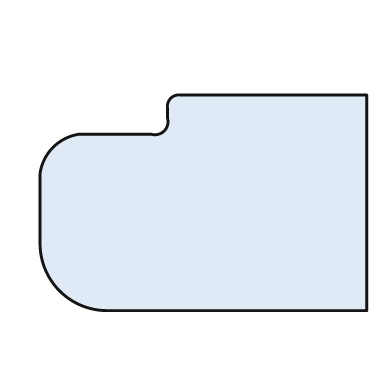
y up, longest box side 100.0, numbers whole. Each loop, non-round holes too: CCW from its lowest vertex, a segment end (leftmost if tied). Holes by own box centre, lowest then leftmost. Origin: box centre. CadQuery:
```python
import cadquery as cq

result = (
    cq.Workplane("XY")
    .moveTo(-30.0, -33.0)
    .lineTo(50.0, -33.0)
    .lineTo(50.0, 33.0)
    .lineTo(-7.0, 33.0)
    .threePointArc((-10.0, 32.0), (-11.0, 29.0))
    .lineTo(-11.0, 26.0)
    .threePointArc((-12.0, 22.0), (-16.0, 21.0))
    .lineTo(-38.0, 21.0)
    .threePointArc((-46.0, 17.0), (-50.0, 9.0))
    .lineTo(-50.0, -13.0)
    .threePointArc((-44.0, -27.0), (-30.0, -33.0))
    .close()
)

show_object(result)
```